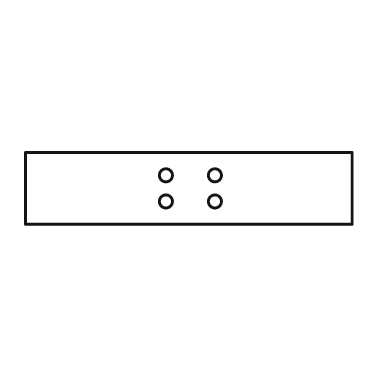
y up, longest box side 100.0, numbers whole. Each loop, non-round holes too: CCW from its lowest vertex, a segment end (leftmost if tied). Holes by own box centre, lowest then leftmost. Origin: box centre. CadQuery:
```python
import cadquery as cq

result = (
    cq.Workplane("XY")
    .moveTo(-50.0, -11.0)
    .lineTo(50.0, -11.0)
    .lineTo(50.0, 11.0)
    .lineTo(-50.0, 11.0)
    .close()
    .moveTo(-7.0, -4.0)
    .circle(2.0)
    .moveTo(8.0, -4.0)
    .circle(2.0)
    .moveTo(-7.0, 4.0)
    .circle(2.0)
    .moveTo(8.0, 4.0)
    .circle(2.0)
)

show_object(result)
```